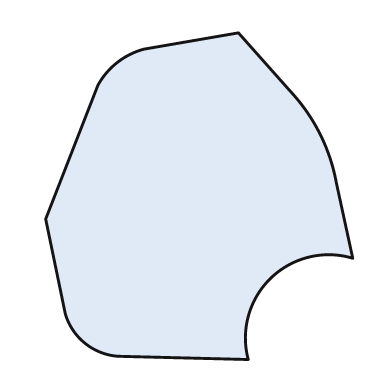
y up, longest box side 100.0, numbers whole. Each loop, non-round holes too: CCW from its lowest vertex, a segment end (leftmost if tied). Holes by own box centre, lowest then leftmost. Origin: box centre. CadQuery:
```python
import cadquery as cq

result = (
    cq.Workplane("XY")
    .moveTo(15.0, -50.0)
    .threePointArc((22.0, -25.0), (47.0, -19.0))
    .lineTo(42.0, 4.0)
    .threePointArc((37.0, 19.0), (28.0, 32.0))
    .lineTo(12.0, 50.0)
    .lineTo(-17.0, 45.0)
    .threePointArc((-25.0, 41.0), (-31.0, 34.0))
    .lineTo(-47.0, -7.0)
    .lineTo(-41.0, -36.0)
    .threePointArc((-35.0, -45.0), (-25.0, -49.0))
    .close()
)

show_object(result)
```